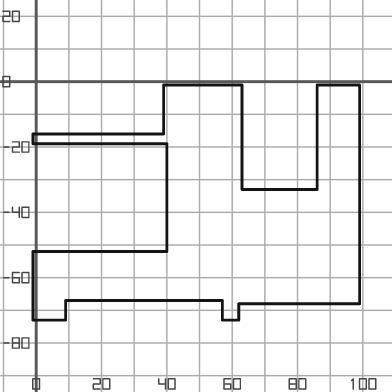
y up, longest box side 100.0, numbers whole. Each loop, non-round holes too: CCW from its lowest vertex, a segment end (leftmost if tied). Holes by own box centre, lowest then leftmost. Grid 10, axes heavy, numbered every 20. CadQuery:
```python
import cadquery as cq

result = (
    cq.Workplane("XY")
    .moveTo(-1.0, -73.0)
    .lineTo(9.0, -73.0)
    .lineTo(9.0, -67.0)
    .lineTo(57.0, -67.0)
    .lineTo(57.0, -73.0)
    .lineTo(62.0, -73.0)
    .lineTo(62.0, -68.0)
    .lineTo(99.0, -68.0)
    .lineTo(99.0, -1.0)
    .lineTo(86.0, -1.0)
    .lineTo(86.0, -33.0)
    .lineTo(63.0, -33.0)
    .lineTo(63.0, -1.0)
    .lineTo(39.0, -1.0)
    .lineTo(39.0, -16.0)
    .lineTo(-1.0, -16.0)
    .lineTo(-1.0, -19.0)
    .lineTo(40.0, -19.0)
    .lineTo(40.0, -52.0)
    .lineTo(-1.0, -52.0)
    .close()
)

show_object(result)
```